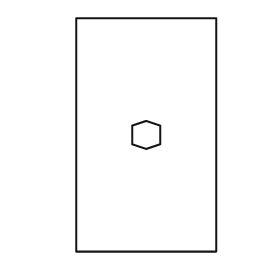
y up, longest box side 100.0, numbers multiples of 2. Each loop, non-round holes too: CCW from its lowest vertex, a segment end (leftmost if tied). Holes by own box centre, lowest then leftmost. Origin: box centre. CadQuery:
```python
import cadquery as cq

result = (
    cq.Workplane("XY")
    .moveTo(-30.0, -50.0)
    .lineTo(30.0, -50.0)
    .lineTo(30.0, 50.0)
    .lineTo(-30.0, 50.0)
    .close()
    .moveTo(0.0, -6.0)
    .lineTo(6.0, -4.0)
    .lineTo(6.0, 4.0)
    .lineTo(0.0, 6.0)
    .lineTo(-6.0, 4.0)
    .lineTo(-6.0, -4.0)
    .close()
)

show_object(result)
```